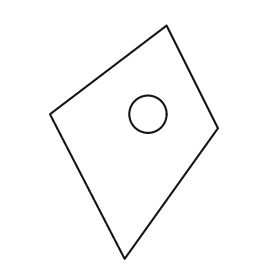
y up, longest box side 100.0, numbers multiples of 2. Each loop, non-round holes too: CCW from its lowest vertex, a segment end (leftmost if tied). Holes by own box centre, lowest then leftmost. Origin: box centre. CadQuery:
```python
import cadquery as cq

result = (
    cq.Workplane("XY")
    .moveTo(-4.0, -50.0)
    .lineTo(36.0, 6.0)
    .lineTo(14.0, 50.0)
    .lineTo(-36.0, 12.0)
    .close()
    .moveTo(6.0, 12.0)
    .circle(8.0)
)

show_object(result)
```